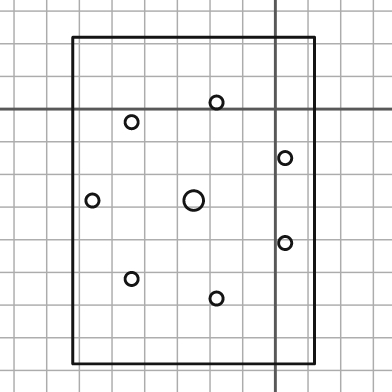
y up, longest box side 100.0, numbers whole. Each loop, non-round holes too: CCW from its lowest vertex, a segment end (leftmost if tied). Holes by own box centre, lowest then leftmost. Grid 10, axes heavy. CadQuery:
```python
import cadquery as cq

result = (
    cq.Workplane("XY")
    .moveTo(-62.0, -78.0)
    .lineTo(12.0, -78.0)
    .lineTo(12.0, 22.0)
    .lineTo(-62.0, 22.0)
    .close()
    .moveTo(-18.0, -58.0)
    .circle(2.0)
    .moveTo(-44.0, -52.0)
    .circle(2.0)
    .moveTo(3.0, -41.0)
    .circle(2.0)
    .moveTo(-56.0, -28.0)
    .circle(2.0)
    .moveTo(-25.0, -28.0)
    .circle(3.0)
    .moveTo(3.0, -15.0)
    .circle(2.0)
    .moveTo(-44.0, -4.0)
    .circle(2.0)
    .moveTo(-18.0, 2.0)
    .circle(2.0)
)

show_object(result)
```